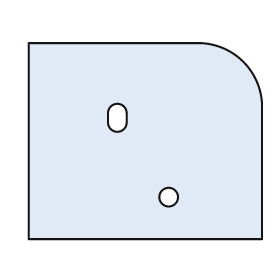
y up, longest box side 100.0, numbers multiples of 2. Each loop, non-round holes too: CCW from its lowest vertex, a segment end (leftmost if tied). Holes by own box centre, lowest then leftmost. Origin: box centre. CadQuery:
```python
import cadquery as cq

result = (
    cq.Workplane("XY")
    .moveTo(-50.0, -42.0)
    .lineTo(50.0, -42.0)
    .lineTo(50.0, 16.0)
    .threePointArc((42.0, 34.0), (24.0, 42.0))
    .lineTo(-50.0, 42.0)
    .close()
    .moveTo(10.0, -24.0)
    .circle(4.0)
    .moveTo(-16.0, 8.0)
    .threePointArc((-12.0, 4.0), (-8.0, 8.0))
    .lineTo(-8.0, 12.0)
    .threePointArc((-12.0, 16.0), (-16.0, 12.0))
    .close()
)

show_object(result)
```